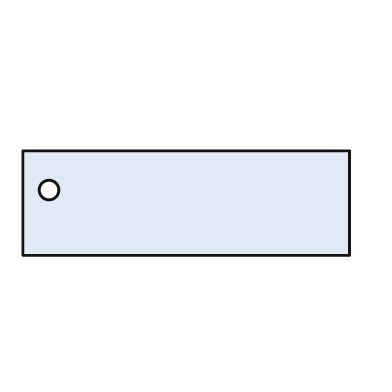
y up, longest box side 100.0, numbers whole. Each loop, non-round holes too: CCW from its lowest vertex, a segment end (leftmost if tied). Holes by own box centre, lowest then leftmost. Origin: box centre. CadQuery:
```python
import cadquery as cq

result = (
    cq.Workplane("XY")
    .moveTo(-50.0, -16.0)
    .lineTo(50.0, -16.0)
    .lineTo(50.0, 16.0)
    .lineTo(-50.0, 16.0)
    .close()
    .moveTo(-42.0, 4.0)
    .circle(3.0)
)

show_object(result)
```